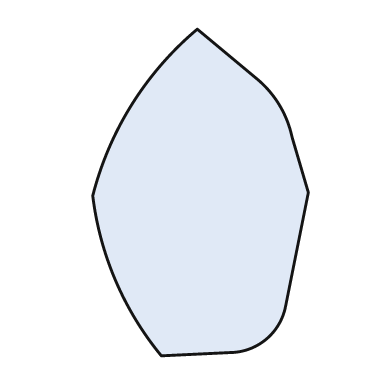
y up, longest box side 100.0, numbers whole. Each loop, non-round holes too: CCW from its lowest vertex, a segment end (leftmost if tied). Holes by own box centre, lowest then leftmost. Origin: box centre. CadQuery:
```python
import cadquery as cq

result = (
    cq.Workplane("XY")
    .moveTo(-12.0, -50.0)
    .lineTo(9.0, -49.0)
    .threePointArc((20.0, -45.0), (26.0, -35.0))
    .lineTo(33.0, 0.0)
    .lineTo(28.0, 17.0)
    .threePointArc((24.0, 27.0), (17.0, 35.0))
    .lineTo(-1.0, 50.0)
    .threePointArc((-21.0, 27.0), (-33.0, -1.0))
    .threePointArc((-26.0, -27.0), (-12.0, -50.0))
    .close()
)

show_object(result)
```